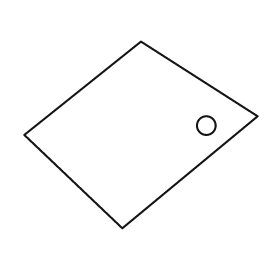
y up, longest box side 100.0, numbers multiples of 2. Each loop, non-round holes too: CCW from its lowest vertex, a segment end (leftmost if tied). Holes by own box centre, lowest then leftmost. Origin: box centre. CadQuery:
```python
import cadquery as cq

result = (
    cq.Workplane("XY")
    .moveTo(-8.0, -40.0)
    .lineTo(50.0, 8.0)
    .lineTo(0.0, 40.0)
    .lineTo(-50.0, 0.0)
    .close()
    .moveTo(28.0, 4.0)
    .circle(4.0)
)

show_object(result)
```